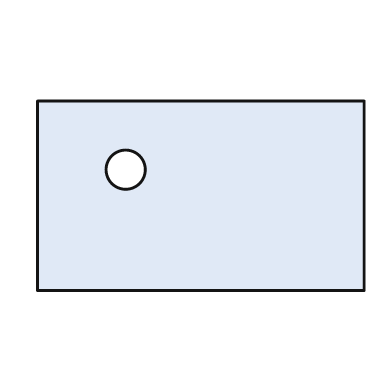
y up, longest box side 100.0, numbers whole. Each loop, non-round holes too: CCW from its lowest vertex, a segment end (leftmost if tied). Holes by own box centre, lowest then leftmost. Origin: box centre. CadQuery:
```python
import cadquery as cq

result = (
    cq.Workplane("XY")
    .moveTo(-50.0, -29.0)
    .lineTo(50.0, -29.0)
    .lineTo(50.0, 29.0)
    .lineTo(-50.0, 29.0)
    .close()
    .moveTo(-23.0, 8.0)
    .circle(6.0)
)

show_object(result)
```